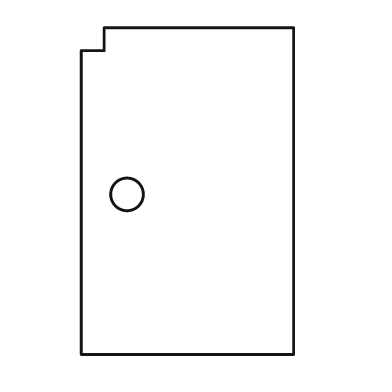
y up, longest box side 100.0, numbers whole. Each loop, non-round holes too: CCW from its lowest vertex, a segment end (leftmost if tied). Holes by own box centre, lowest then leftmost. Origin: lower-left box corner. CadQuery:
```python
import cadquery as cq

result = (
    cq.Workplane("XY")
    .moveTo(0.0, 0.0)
    .lineTo(65.0, 0.0)
    .lineTo(65.0, 100.0)
    .lineTo(7.0, 100.0)
    .lineTo(7.0, 93.0)
    .lineTo(0.0, 93.0)
    .close()
    .moveTo(14.0, 49.0)
    .circle(5.0)
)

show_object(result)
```